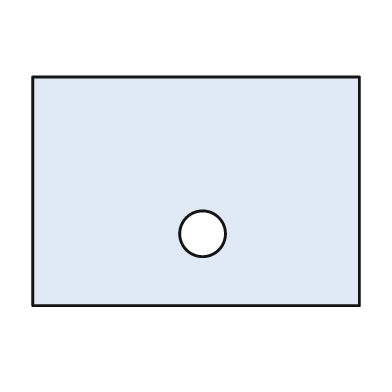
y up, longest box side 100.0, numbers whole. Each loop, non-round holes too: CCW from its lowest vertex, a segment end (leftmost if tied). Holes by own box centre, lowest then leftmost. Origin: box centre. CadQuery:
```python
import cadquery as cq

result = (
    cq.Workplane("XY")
    .moveTo(-50.0, -35.0)
    .lineTo(50.0, -35.0)
    .lineTo(50.0, 35.0)
    .lineTo(-50.0, 35.0)
    .close()
    .moveTo(2.0, -13.0)
    .circle(7.0)
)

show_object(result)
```